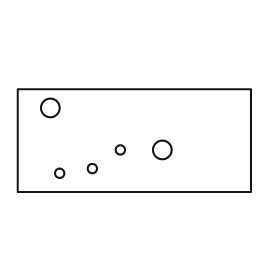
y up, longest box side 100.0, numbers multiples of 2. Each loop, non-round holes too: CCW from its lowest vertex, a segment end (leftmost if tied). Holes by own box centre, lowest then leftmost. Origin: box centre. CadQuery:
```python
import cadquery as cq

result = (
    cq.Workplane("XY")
    .moveTo(-50.0, -22.0)
    .lineTo(50.0, -22.0)
    .lineTo(50.0, 22.0)
    .lineTo(-50.0, 22.0)
    .close()
    .moveTo(-32.0, -14.0)
    .circle(2.0)
    .moveTo(-18.0, -12.0)
    .circle(2.0)
    .moveTo(-6.0, -4.0)
    .circle(2.0)
    .moveTo(12.0, -4.0)
    .circle(4.0)
    .moveTo(-36.0, 14.0)
    .circle(4.0)
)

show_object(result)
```